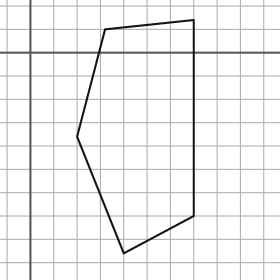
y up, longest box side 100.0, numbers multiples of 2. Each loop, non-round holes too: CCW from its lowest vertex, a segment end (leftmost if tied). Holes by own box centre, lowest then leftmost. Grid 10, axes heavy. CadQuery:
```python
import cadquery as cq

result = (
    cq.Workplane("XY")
    .moveTo(40.0, -86.0)
    .lineTo(70.0, -70.0)
    .lineTo(70.0, 14.0)
    .lineTo(32.0, 10.0)
    .lineTo(20.0, -36.0)
    .close()
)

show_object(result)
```